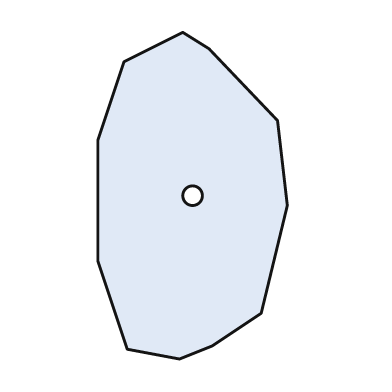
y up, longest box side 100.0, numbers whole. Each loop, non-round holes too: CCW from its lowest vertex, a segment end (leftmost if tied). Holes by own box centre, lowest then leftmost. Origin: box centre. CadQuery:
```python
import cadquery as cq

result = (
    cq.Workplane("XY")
    .moveTo(-4.0, -50.0)
    .lineTo(6.0, -46.0)
    .lineTo(21.0, -36.0)
    .lineTo(29.0, -3.0)
    .lineTo(26.0, 23.0)
    .lineTo(5.0, 45.0)
    .lineTo(-3.0, 50.0)
    .lineTo(-21.0, 41.0)
    .lineTo(-29.0, 17.0)
    .lineTo(-29.0, -20.0)
    .lineTo(-20.0, -47.0)
    .close()
    .moveTo(0.0, 0.0)
    .circle(3.0)
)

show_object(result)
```